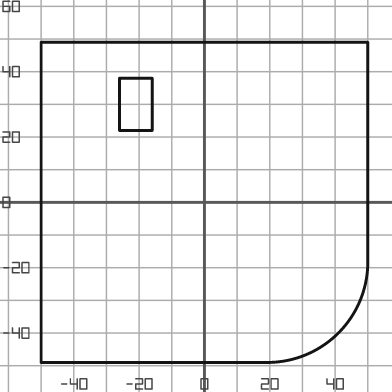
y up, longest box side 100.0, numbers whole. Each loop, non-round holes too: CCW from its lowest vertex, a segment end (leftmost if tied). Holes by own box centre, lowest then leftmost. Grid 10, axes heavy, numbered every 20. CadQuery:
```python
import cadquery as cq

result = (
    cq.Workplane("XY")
    .moveTo(-50.0, -49.0)
    .lineTo(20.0, -49.0)
    .threePointArc((41.0, -40.0), (50.0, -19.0))
    .lineTo(50.0, 49.0)
    .lineTo(-50.0, 49.0)
    .close()
    .moveTo(-26.0, 22.0)
    .lineTo(-16.0, 22.0)
    .lineTo(-16.0, 38.0)
    .lineTo(-26.0, 38.0)
    .close()
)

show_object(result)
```